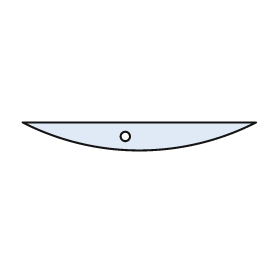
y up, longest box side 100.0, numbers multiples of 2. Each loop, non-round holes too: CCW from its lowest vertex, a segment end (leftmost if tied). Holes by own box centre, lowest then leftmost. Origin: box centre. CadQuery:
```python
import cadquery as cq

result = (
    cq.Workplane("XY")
    .moveTo(-50.0, 6.0)
    .threePointArc((0.0, -6.0), (50.0, 6.0))
    .close()
    .moveTo(-6.0, 0.0)
    .circle(2.0)
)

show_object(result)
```